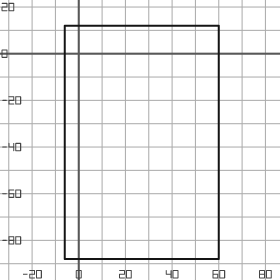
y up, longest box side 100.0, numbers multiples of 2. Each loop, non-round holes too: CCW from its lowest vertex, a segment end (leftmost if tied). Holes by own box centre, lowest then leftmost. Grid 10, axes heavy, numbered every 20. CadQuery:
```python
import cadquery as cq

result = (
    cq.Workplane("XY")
    .moveTo(-6.0, -88.0)
    .lineTo(60.0, -88.0)
    .lineTo(60.0, 12.0)
    .lineTo(-6.0, 12.0)
    .close()
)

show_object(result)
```